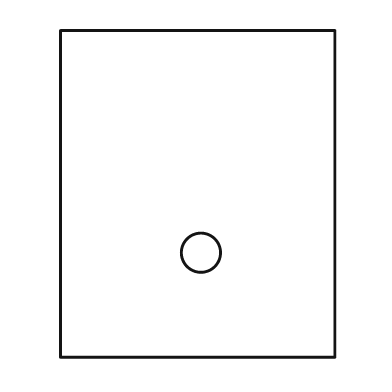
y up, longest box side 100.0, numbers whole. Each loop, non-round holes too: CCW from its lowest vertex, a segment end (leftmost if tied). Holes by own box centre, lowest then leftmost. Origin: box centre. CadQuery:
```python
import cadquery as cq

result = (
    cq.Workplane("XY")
    .moveTo(-42.0, -50.0)
    .lineTo(42.0, -50.0)
    .lineTo(42.0, 50.0)
    .lineTo(-42.0, 50.0)
    .close()
    .moveTo(1.0, -18.0)
    .circle(6.0)
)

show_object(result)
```